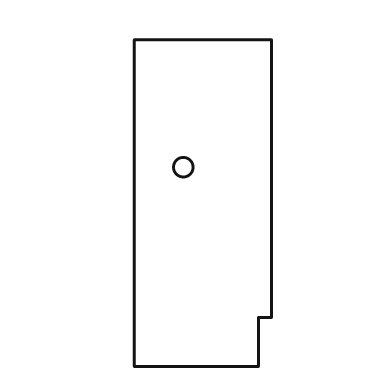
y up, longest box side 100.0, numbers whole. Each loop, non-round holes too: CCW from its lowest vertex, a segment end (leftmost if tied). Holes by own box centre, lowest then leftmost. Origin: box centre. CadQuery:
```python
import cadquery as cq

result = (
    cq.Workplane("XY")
    .moveTo(-21.0, -50.0)
    .lineTo(17.0, -50.0)
    .lineTo(17.0, -35.0)
    .lineTo(21.0, -35.0)
    .lineTo(21.0, 50.0)
    .lineTo(-21.0, 50.0)
    .close()
    .moveTo(-6.0, 11.0)
    .circle(3.0)
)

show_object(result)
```